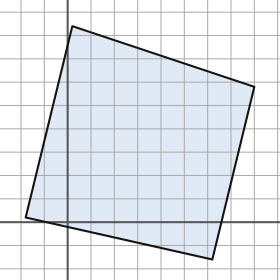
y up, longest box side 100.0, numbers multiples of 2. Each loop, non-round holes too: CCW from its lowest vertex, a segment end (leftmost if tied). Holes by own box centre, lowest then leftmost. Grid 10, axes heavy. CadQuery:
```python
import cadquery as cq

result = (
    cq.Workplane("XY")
    .moveTo(62.0, -16.0)
    .lineTo(80.0, 58.0)
    .lineTo(2.0, 84.0)
    .lineTo(-18.0, 2.0)
    .close()
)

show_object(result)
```